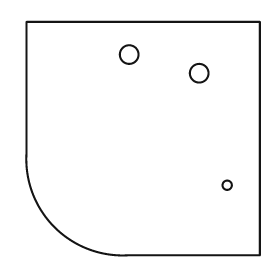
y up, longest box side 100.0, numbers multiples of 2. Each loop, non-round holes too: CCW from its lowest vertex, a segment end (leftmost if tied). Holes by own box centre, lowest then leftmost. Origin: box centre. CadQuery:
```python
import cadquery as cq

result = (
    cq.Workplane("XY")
    .moveTo(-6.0, -50.0)
    .lineTo(50.0, -50.0)
    .lineTo(50.0, 50.0)
    .lineTo(-50.0, 50.0)
    .lineTo(-50.0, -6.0)
    .threePointArc((-38.0, -38.0), (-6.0, -50.0))
    .close()
    .moveTo(36.0, -20.0)
    .circle(2.0)
    .moveTo(24.0, 28.0)
    .circle(4.0)
    .moveTo(-6.0, 36.0)
    .circle(4.0)
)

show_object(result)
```